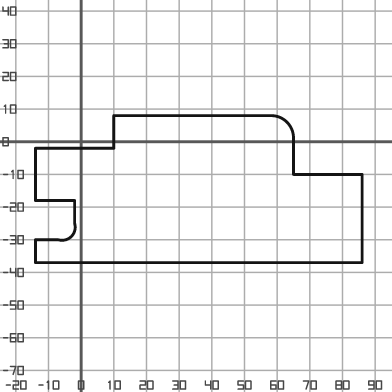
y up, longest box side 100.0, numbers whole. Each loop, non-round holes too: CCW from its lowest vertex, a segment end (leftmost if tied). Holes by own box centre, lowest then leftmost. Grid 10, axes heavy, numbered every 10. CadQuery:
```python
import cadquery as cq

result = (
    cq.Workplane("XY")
    .moveTo(-14.0, -37.0)
    .lineTo(86.0, -37.0)
    .lineTo(86.0, -10.0)
    .lineTo(65.0, -10.0)
    .lineTo(65.0, 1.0)
    .threePointArc((63.0, 6.0), (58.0, 8.0))
    .lineTo(10.0, 8.0)
    .lineTo(10.0, -2.0)
    .lineTo(-14.0, -2.0)
    .lineTo(-14.0, -18.0)
    .lineTo(-2.0, -18.0)
    .lineTo(-2.0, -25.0)
    .threePointArc((-3.0, -29.0), (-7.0, -30.0))
    .lineTo(-14.0, -30.0)
    .close()
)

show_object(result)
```